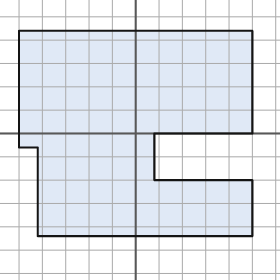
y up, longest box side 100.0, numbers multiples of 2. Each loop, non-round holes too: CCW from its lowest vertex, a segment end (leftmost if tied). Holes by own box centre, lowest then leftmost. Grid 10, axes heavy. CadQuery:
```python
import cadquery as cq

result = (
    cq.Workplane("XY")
    .moveTo(-42.0, -44.0)
    .lineTo(50.0, -44.0)
    .lineTo(50.0, -20.0)
    .lineTo(8.0, -20.0)
    .lineTo(8.0, 0.0)
    .lineTo(50.0, 0.0)
    .lineTo(50.0, 44.0)
    .lineTo(-50.0, 44.0)
    .lineTo(-50.0, -6.0)
    .lineTo(-42.0, -6.0)
    .close()
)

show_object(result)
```